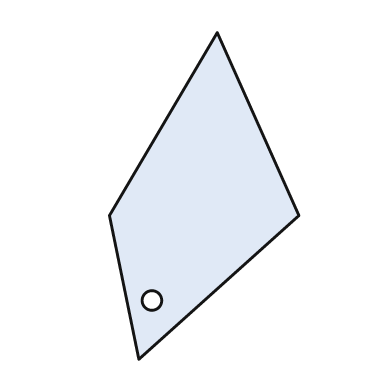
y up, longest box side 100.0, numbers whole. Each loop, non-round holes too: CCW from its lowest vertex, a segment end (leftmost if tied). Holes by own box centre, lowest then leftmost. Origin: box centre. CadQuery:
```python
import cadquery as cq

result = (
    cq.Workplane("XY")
    .moveTo(-20.0, -50.0)
    .lineTo(29.0, -6.0)
    .lineTo(4.0, 50.0)
    .lineTo(-29.0, -6.0)
    .close()
    .moveTo(-16.0, -32.0)
    .circle(3.0)
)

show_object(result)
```